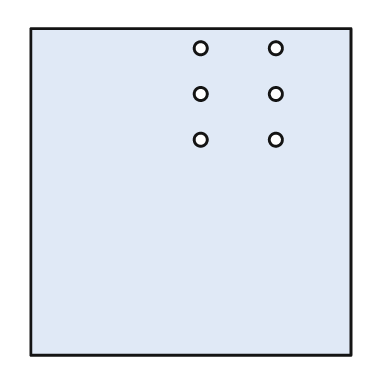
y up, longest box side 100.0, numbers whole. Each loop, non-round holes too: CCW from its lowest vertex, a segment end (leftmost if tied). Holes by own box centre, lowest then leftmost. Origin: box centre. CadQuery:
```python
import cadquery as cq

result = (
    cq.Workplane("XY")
    .moveTo(-49.0, -50.0)
    .lineTo(49.0, -50.0)
    .lineTo(49.0, 50.0)
    .lineTo(-49.0, 50.0)
    .close()
    .moveTo(3.0, 16.0)
    .circle(2.0)
    .moveTo(26.0, 16.0)
    .circle(2.0)
    .moveTo(3.0, 30.0)
    .circle(2.0)
    .moveTo(26.0, 30.0)
    .circle(2.0)
    .moveTo(3.0, 44.0)
    .circle(2.0)
    .moveTo(26.0, 44.0)
    .circle(2.0)
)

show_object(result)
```